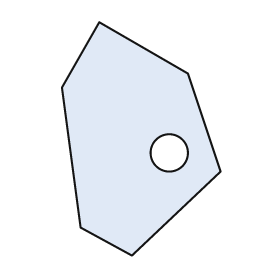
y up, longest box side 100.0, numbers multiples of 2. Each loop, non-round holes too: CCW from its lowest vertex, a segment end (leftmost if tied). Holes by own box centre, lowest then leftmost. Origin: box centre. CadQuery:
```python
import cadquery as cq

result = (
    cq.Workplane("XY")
    .moveTo(-4.0, -50.0)
    .lineTo(34.0, -14.0)
    .lineTo(20.0, 28.0)
    .lineTo(-18.0, 50.0)
    .lineTo(-34.0, 22.0)
    .lineTo(-26.0, -38.0)
    .close()
    .moveTo(12.0, -6.0)
    .circle(8.0)
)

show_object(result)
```